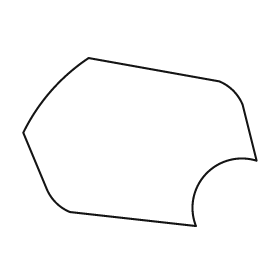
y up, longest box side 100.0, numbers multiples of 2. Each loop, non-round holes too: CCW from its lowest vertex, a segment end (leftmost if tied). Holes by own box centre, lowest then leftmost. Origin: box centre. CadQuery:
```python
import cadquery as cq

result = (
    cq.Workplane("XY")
    .moveTo(24.0, -36.0)
    .threePointArc((28.0, -14.0), (50.0, -8.0))
    .lineTo(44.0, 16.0)
    .threePointArc((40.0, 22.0), (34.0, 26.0))
    .lineTo(-22.0, 36.0)
    .threePointArc((-38.0, 22.0), (-50.0, 4.0))
    .lineTo(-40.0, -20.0)
    .threePointArc((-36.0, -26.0), (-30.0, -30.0))
    .close()
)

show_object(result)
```